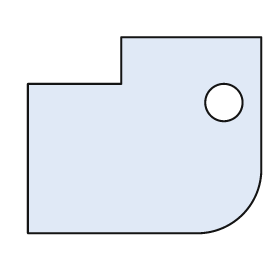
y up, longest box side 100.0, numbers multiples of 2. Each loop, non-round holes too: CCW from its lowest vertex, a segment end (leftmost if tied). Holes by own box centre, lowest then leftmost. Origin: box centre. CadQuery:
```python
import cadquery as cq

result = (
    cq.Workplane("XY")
    .moveTo(-50.0, -42.0)
    .lineTo(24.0, -42.0)
    .threePointArc((42.0, -34.0), (50.0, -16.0))
    .lineTo(50.0, 42.0)
    .lineTo(-10.0, 42.0)
    .lineTo(-10.0, 22.0)
    .lineTo(-50.0, 22.0)
    .close()
    .moveTo(34.0, 14.0)
    .circle(8.0)
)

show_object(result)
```